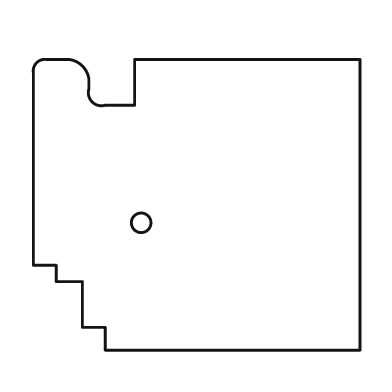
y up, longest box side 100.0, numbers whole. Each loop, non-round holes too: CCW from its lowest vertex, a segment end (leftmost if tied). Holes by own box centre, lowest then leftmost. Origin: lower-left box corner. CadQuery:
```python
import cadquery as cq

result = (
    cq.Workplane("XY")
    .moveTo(22.0, 0.0)
    .lineTo(100.0, 0.0)
    .lineTo(100.0, 89.0)
    .lineTo(31.0, 89.0)
    .lineTo(31.0, 75.0)
    .lineTo(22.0, 75.0)
    .threePointArc((18.0, 76.0), (17.0, 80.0))
    .lineTo(17.0, 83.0)
    .threePointArc((15.0, 87.0), (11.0, 89.0))
    .lineTo(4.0, 89.0)
    .threePointArc((1.0, 88.0), (0.0, 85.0))
    .lineTo(0.0, 26.0)
    .lineTo(7.0, 26.0)
    .lineTo(7.0, 21.0)
    .lineTo(15.0, 21.0)
    .lineTo(15.0, 7.0)
    .lineTo(22.0, 7.0)
    .close()
    .moveTo(33.0, 39.0)
    .circle(3.0)
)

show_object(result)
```